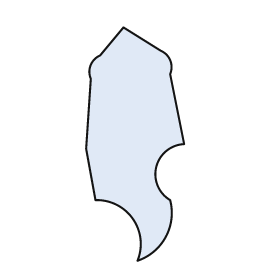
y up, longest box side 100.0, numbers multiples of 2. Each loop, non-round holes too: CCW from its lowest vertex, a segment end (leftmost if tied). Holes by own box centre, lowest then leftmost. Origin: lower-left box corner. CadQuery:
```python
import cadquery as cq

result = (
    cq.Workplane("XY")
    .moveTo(22.0, 0.0)
    .threePointArc((34.0, 10.0), (36.0, 26.0))
    .threePointArc((30.0, 40.0), (42.0, 50.0))
    .lineTo(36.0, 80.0)
    .threePointArc((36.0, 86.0), (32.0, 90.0))
    .lineTo(16.0, 100.0)
    .lineTo(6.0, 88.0)
    .threePointArc((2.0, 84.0), (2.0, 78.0))
    .lineTo(0.0, 48.0)
    .lineTo(4.0, 26.0)
    .threePointArc((20.0, 18.0), (22.0, 0.0))
    .close()
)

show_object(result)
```